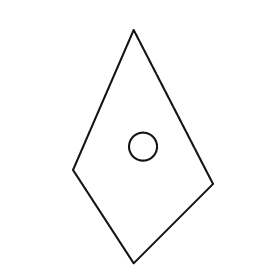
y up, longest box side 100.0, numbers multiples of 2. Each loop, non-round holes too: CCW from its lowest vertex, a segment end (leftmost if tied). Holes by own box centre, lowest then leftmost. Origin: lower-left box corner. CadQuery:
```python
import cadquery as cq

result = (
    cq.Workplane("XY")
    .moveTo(26.0, 0.0)
    .lineTo(60.0, 34.0)
    .lineTo(26.0, 100.0)
    .lineTo(0.0, 40.0)
    .close()
    .moveTo(30.0, 50.0)
    .circle(6.0)
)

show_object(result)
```